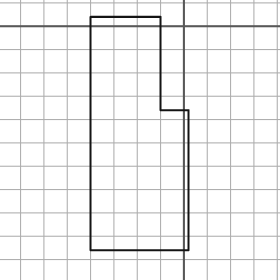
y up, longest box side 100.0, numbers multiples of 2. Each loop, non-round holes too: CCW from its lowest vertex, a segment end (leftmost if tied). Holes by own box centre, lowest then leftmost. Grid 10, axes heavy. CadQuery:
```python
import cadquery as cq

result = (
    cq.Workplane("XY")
    .moveTo(-40.0, -96.0)
    .lineTo(2.0, -96.0)
    .lineTo(2.0, -36.0)
    .lineTo(-10.0, -36.0)
    .lineTo(-10.0, 4.0)
    .lineTo(-40.0, 4.0)
    .close()
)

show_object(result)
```